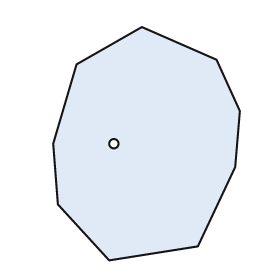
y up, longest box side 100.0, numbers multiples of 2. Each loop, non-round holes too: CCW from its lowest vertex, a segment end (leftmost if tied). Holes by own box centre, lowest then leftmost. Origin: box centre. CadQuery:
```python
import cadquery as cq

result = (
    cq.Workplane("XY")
    .moveTo(-16.0, -50.0)
    .lineTo(22.0, -44.0)
    .lineTo(38.0, -10.0)
    .lineTo(40.0, 14.0)
    .lineTo(30.0, 36.0)
    .lineTo(-2.0, 50.0)
    .lineTo(-30.0, 34.0)
    .lineTo(-40.0, 0.0)
    .lineTo(-38.0, -26.0)
    .close()
    .moveTo(-14.0, 0.0)
    .circle(2.0)
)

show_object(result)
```